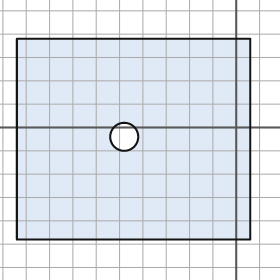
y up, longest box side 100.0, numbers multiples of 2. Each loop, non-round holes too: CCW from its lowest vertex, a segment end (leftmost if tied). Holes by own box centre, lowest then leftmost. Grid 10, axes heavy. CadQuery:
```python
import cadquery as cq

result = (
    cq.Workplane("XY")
    .moveTo(-94.0, -48.0)
    .lineTo(6.0, -48.0)
    .lineTo(6.0, 38.0)
    .lineTo(-94.0, 38.0)
    .close()
    .moveTo(-48.0, -4.0)
    .circle(6.0)
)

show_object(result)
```